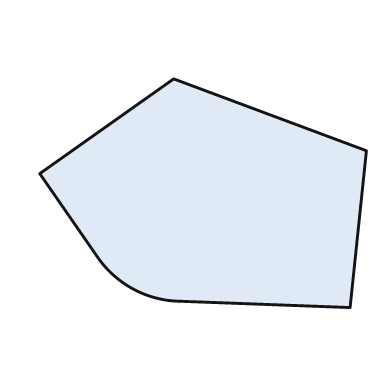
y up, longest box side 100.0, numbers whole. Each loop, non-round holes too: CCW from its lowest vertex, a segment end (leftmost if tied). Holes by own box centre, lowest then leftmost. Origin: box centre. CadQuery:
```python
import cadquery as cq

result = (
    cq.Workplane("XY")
    .moveTo(45.0, -35.0)
    .lineTo(50.0, 13.0)
    .lineTo(-9.0, 35.0)
    .lineTo(-50.0, 6.0)
    .lineTo(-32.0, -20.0)
    .threePointArc((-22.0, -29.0), (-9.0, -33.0))
    .close()
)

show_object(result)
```